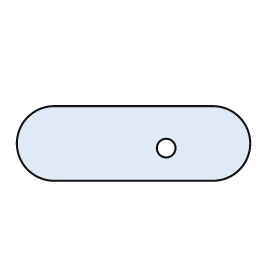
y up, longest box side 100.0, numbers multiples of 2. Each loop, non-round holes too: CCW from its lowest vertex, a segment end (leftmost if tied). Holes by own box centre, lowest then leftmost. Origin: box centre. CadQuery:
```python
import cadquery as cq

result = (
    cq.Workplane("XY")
    .moveTo(-34.0, -16.0)
    .lineTo(34.0, -16.0)
    .threePointArc((50.0, 0.0), (34.0, 16.0))
    .lineTo(-34.0, 16.0)
    .threePointArc((-50.0, 0.0), (-34.0, -16.0))
    .close()
    .moveTo(14.0, -2.0)
    .circle(4.0)
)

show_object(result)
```